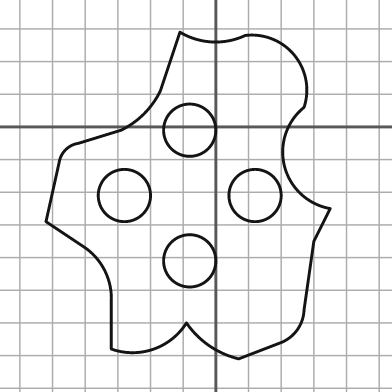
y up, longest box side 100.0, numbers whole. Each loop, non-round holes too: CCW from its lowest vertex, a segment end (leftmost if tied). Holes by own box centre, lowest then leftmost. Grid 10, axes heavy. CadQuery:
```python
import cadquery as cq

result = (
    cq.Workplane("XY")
    .moveTo(7.0, -71.0)
    .lineTo(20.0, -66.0)
    .threePointArc((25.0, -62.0), (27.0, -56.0))
    .lineTo(30.0, -35.0)
    .lineTo(35.0, -25.0)
    .threePointArc((21.0, -12.0), (27.0, 6.0))
    .threePointArc((24.0, 22.0), (9.0, 28.0))
    .threePointArc((-1.0, 26.0), (-11.0, 29.0))
    .lineTo(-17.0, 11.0)
    .threePointArc((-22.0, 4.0), (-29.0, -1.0))
    .lineTo(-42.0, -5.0)
    .threePointArc((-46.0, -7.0), (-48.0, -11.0))
    .lineTo(-52.0, -29.0)
    .lineTo(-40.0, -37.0)
    .threePointArc((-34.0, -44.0), (-32.0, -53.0))
    .lineTo(-32.0, -68.0)
    .threePointArc((-19.0, -68.0), (-9.0, -60.0))
    .threePointArc((-2.0, -67.0), (7.0, -71.0))
    .close()
    .moveTo(-8.0, -41.0)
    .circle(8.0)
    .moveTo(-28.0, -21.0)
    .circle(8.0)
    .moveTo(12.0, -21.0)
    .circle(8.0)
    .moveTo(-8.0, -1.0)
    .circle(8.0)
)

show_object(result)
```